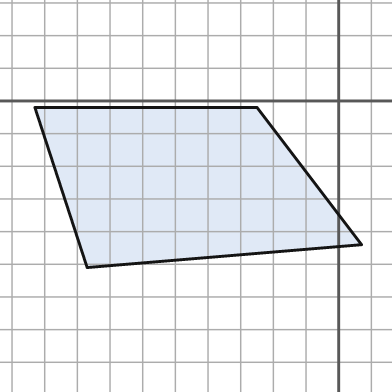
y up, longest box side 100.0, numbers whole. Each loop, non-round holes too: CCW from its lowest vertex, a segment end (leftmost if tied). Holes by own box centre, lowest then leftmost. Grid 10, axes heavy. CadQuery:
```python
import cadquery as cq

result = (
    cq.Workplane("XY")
    .moveTo(-77.0, -51.0)
    .lineTo(7.0, -44.0)
    .lineTo(-25.0, -2.0)
    .lineTo(-93.0, -2.0)
    .close()
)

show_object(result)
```